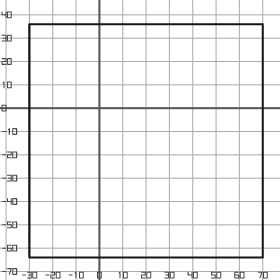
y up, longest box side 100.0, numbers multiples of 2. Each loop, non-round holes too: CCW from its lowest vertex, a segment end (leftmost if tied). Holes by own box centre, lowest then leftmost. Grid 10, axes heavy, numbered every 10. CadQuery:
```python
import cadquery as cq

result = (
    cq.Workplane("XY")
    .moveTo(-30.0, -64.0)
    .lineTo(70.0, -64.0)
    .lineTo(70.0, 36.0)
    .lineTo(-30.0, 36.0)
    .close()
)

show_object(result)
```